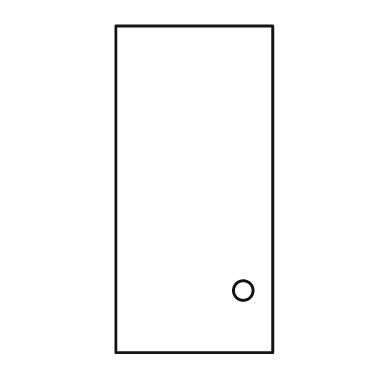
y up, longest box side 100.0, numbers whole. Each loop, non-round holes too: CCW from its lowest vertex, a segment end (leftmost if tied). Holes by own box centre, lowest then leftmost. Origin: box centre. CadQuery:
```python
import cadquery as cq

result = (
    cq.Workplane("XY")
    .moveTo(-24.0, -50.0)
    .lineTo(24.0, -50.0)
    .lineTo(24.0, 50.0)
    .lineTo(-24.0, 50.0)
    .close()
    .moveTo(15.0, -31.0)
    .circle(3.0)
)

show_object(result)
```